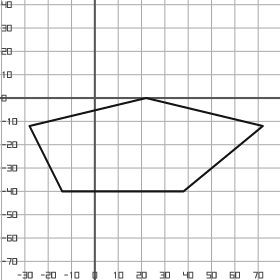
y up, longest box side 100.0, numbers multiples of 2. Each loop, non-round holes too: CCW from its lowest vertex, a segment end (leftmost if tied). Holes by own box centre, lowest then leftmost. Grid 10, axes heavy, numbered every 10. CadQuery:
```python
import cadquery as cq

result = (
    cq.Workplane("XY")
    .moveTo(-14.0, -40.0)
    .lineTo(38.0, -40.0)
    .lineTo(72.0, -12.0)
    .lineTo(22.0, 0.0)
    .lineTo(-28.0, -12.0)
    .close()
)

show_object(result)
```